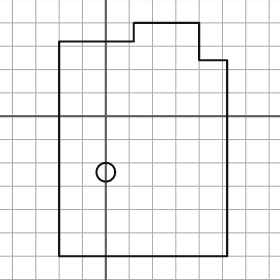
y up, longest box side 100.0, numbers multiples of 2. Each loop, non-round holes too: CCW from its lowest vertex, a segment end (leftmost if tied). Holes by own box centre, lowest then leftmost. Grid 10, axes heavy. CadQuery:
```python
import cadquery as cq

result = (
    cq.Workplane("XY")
    .moveTo(-20.0, -60.0)
    .lineTo(52.0, -60.0)
    .lineTo(52.0, 24.0)
    .lineTo(40.0, 24.0)
    .lineTo(40.0, 40.0)
    .lineTo(12.0, 40.0)
    .lineTo(12.0, 32.0)
    .lineTo(-20.0, 32.0)
    .close()
    .moveTo(0.0, -24.0)
    .circle(4.0)
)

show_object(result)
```